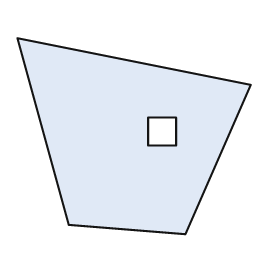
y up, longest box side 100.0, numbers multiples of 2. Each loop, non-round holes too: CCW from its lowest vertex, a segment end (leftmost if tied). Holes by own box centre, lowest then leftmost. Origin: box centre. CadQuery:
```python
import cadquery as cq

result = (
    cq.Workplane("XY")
    .moveTo(22.0, -42.0)
    .lineTo(50.0, 22.0)
    .lineTo(-50.0, 42.0)
    .lineTo(-28.0, -38.0)
    .close()
    .moveTo(6.0, -4.0)
    .lineTo(18.0, -4.0)
    .lineTo(18.0, 8.0)
    .lineTo(6.0, 8.0)
    .close()
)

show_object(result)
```